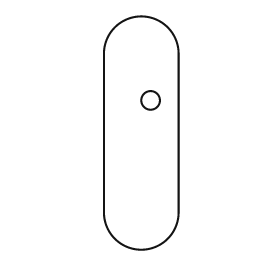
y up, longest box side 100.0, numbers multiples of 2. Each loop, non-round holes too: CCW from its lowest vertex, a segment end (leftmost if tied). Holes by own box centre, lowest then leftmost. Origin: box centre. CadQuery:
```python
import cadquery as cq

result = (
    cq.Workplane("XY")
    .moveTo(-16.0, -34.0)
    .threePointArc((0.0, -50.0), (16.0, -34.0))
    .lineTo(16.0, 34.0)
    .threePointArc((0.0, 50.0), (-16.0, 34.0))
    .close()
    .moveTo(4.0, 14.0)
    .circle(4.0)
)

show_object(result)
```